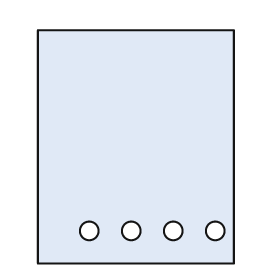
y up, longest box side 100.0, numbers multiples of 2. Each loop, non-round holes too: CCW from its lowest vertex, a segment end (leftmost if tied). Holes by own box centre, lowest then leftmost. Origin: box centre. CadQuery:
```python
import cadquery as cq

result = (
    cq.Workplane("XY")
    .moveTo(-42.0, -50.0)
    .lineTo(42.0, -50.0)
    .lineTo(42.0, 50.0)
    .lineTo(-42.0, 50.0)
    .close()
    .moveTo(-20.0, -36.0)
    .circle(4.0)
    .moveTo(-2.0, -36.0)
    .circle(4.0)
    .moveTo(16.0, -36.0)
    .circle(4.0)
    .moveTo(34.0, -36.0)
    .circle(4.0)
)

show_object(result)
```